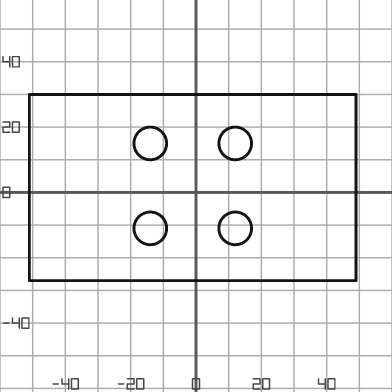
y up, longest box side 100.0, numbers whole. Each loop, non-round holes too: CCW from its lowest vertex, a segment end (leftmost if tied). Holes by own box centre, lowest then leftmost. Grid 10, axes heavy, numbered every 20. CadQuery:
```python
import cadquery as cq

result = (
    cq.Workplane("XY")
    .moveTo(-51.0, -27.0)
    .lineTo(49.0, -27.0)
    .lineTo(49.0, 30.0)
    .lineTo(-51.0, 30.0)
    .close()
    .moveTo(-14.0, -11.0)
    .circle(5.0)
    .moveTo(12.0, -11.0)
    .circle(5.0)
    .moveTo(-14.0, 15.0)
    .circle(5.0)
    .moveTo(12.0, 15.0)
    .circle(5.0)
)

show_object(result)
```